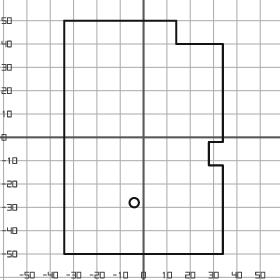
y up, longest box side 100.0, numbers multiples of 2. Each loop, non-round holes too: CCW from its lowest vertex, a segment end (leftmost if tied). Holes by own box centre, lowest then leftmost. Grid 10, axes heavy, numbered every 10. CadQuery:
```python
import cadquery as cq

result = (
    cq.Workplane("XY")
    .moveTo(-34.0, -50.0)
    .lineTo(34.0, -50.0)
    .lineTo(34.0, -12.0)
    .lineTo(28.0, -12.0)
    .lineTo(28.0, -2.0)
    .lineTo(34.0, -2.0)
    .lineTo(34.0, 40.0)
    .lineTo(14.0, 40.0)
    .lineTo(14.0, 50.0)
    .lineTo(-34.0, 50.0)
    .close()
    .moveTo(-4.0, -28.0)
    .circle(2.0)
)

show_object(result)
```